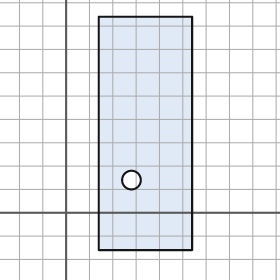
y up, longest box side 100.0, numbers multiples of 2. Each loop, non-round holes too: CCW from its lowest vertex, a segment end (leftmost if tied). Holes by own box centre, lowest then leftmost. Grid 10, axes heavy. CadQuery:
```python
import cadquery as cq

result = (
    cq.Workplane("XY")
    .moveTo(14.0, -16.0)
    .lineTo(54.0, -16.0)
    .lineTo(54.0, 84.0)
    .lineTo(14.0, 84.0)
    .close()
    .moveTo(28.0, 14.0)
    .circle(4.0)
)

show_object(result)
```